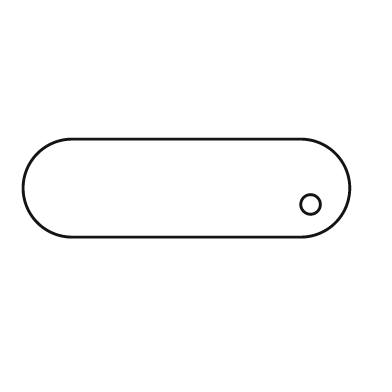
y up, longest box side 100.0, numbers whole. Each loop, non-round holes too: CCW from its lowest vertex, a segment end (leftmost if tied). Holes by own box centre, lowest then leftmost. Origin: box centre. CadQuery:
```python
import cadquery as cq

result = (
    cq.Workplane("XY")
    .moveTo(-35.0, -15.0)
    .lineTo(35.0, -15.0)
    .threePointArc((50.0, 0.0), (35.0, 15.0))
    .lineTo(-35.0, 15.0)
    .threePointArc((-50.0, 0.0), (-35.0, -15.0))
    .close()
    .moveTo(38.0, -5.0)
    .circle(3.0)
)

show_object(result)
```